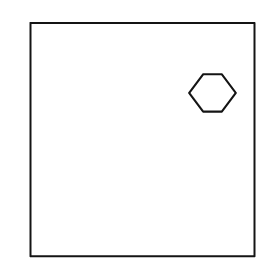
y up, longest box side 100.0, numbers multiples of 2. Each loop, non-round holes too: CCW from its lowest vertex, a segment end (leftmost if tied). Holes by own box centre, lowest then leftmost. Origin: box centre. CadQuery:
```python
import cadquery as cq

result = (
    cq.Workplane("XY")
    .moveTo(-48.0, -50.0)
    .lineTo(48.0, -50.0)
    .lineTo(48.0, 50.0)
    .lineTo(-48.0, 50.0)
    .close()
    .moveTo(26.0, 12.0)
    .lineTo(34.0, 12.0)
    .lineTo(40.0, 20.0)
    .lineTo(34.0, 28.0)
    .lineTo(26.0, 28.0)
    .lineTo(20.0, 20.0)
    .close()
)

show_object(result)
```